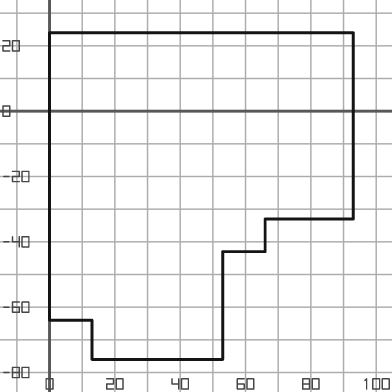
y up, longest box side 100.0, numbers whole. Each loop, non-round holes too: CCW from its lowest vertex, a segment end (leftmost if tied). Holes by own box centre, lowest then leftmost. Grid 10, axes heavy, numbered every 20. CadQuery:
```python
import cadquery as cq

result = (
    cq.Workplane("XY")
    .moveTo(13.0, -76.0)
    .lineTo(53.0, -76.0)
    .lineTo(53.0, -43.0)
    .lineTo(66.0, -43.0)
    .lineTo(66.0, -33.0)
    .lineTo(93.0, -33.0)
    .lineTo(93.0, 24.0)
    .lineTo(0.0, 24.0)
    .lineTo(0.0, -64.0)
    .lineTo(13.0, -64.0)
    .close()
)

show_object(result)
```